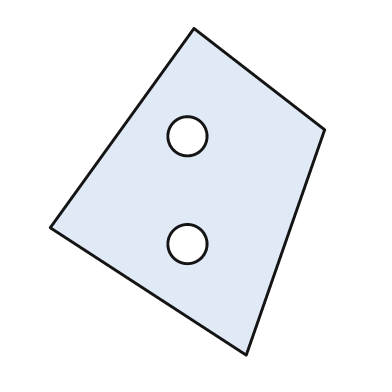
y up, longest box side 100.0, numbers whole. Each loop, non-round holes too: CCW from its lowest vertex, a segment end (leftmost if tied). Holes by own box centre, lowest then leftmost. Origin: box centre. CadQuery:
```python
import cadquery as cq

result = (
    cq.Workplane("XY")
    .moveTo(18.0, -50.0)
    .lineTo(42.0, 19.0)
    .lineTo(2.0, 50.0)
    .lineTo(-42.0, -11.0)
    .close()
    .moveTo(0.0, -16.0)
    .circle(6.0)
    .moveTo(0.0, 17.0)
    .circle(6.0)
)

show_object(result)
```